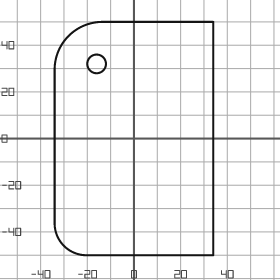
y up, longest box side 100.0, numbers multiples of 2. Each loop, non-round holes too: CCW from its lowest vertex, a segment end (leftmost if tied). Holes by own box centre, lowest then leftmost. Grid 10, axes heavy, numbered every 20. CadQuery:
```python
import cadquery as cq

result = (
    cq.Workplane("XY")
    .moveTo(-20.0, -50.0)
    .lineTo(34.0, -50.0)
    .lineTo(34.0, 50.0)
    .lineTo(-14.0, 50.0)
    .threePointArc((-28.0, 44.0), (-34.0, 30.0))
    .lineTo(-34.0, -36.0)
    .threePointArc((-30.0, -46.0), (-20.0, -50.0))
    .close()
    .moveTo(-16.0, 32.0)
    .circle(4.0)
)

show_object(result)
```